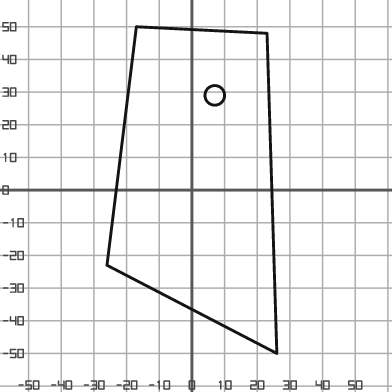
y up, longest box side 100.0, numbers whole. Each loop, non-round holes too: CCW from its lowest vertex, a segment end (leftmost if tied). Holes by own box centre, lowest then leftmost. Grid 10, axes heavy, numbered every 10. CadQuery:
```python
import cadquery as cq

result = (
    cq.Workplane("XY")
    .moveTo(26.0, -50.0)
    .lineTo(23.0, 48.0)
    .lineTo(-17.0, 50.0)
    .lineTo(-26.0, -23.0)
    .close()
    .moveTo(7.0, 29.0)
    .circle(3.0)
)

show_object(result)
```